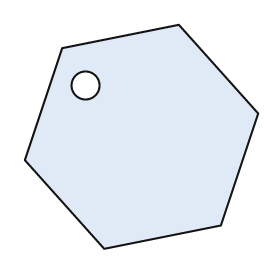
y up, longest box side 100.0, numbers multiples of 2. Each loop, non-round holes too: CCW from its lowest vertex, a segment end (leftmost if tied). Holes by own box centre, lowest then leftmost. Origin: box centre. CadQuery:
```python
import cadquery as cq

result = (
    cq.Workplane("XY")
    .moveTo(-16.0, -48.0)
    .lineTo(34.0, -38.0)
    .lineTo(50.0, 10.0)
    .lineTo(16.0, 48.0)
    .lineTo(-34.0, 38.0)
    .lineTo(-50.0, -10.0)
    .close()
    .moveTo(-24.0, 22.0)
    .circle(6.0)
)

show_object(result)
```